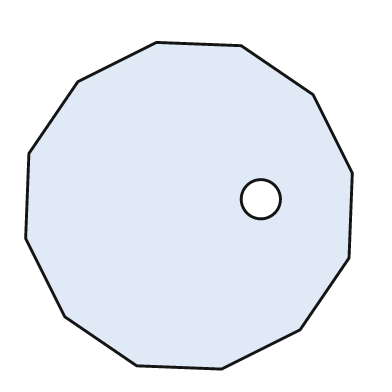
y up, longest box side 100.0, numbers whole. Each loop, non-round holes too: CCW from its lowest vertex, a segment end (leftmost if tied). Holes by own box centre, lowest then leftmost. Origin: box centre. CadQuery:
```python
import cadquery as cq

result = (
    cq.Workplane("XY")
    .moveTo(10.0, -50.0)
    .lineTo(34.0, -38.0)
    .lineTo(49.0, -16.0)
    .lineTo(50.0, 10.0)
    .lineTo(38.0, 34.0)
    .lineTo(16.0, 49.0)
    .lineTo(-10.0, 50.0)
    .lineTo(-34.0, 38.0)
    .lineTo(-49.0, 16.0)
    .lineTo(-50.0, -10.0)
    .lineTo(-38.0, -34.0)
    .lineTo(-16.0, -49.0)
    .close()
    .moveTo(22.0, 2.0)
    .circle(6.0)
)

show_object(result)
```